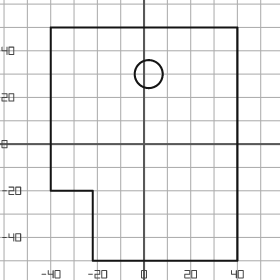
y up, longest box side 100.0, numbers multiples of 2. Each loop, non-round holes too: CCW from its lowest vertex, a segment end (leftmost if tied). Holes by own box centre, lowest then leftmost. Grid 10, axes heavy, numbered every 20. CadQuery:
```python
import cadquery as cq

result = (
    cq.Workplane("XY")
    .moveTo(-22.0, -50.0)
    .lineTo(40.0, -50.0)
    .lineTo(40.0, 50.0)
    .lineTo(-40.0, 50.0)
    .lineTo(-40.0, -20.0)
    .lineTo(-22.0, -20.0)
    .close()
    .moveTo(2.0, 30.0)
    .circle(6.0)
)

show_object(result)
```